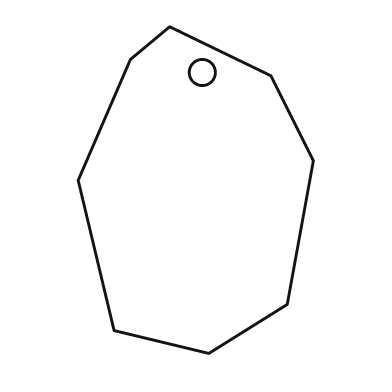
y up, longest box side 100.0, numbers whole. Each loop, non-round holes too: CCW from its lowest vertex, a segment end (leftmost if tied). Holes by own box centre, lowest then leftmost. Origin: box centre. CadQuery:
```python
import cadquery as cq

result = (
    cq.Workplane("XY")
    .moveTo(4.0, -50.0)
    .lineTo(28.0, -35.0)
    .lineTo(36.0, 9.0)
    .lineTo(23.0, 35.0)
    .lineTo(-8.0, 50.0)
    .lineTo(-20.0, 40.0)
    .lineTo(-36.0, 3.0)
    .lineTo(-25.0, -43.0)
    .close()
    .moveTo(2.0, 36.0)
    .circle(4.0)
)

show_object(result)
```